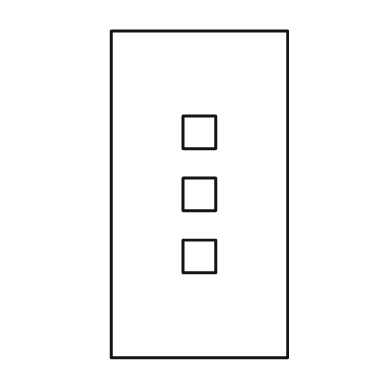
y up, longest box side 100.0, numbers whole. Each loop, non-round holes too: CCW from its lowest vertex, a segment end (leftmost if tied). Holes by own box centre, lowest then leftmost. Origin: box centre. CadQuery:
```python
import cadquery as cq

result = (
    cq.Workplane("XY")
    .moveTo(-27.0, -50.0)
    .lineTo(27.0, -50.0)
    .lineTo(27.0, 50.0)
    .lineTo(-27.0, 50.0)
    .close()
    .moveTo(-5.0, -24.0)
    .lineTo(5.0, -24.0)
    .lineTo(5.0, -14.0)
    .lineTo(-5.0, -14.0)
    .close()
    .moveTo(-5.0, -5.0)
    .lineTo(5.0, -5.0)
    .lineTo(5.0, 5.0)
    .lineTo(-5.0, 5.0)
    .close()
    .moveTo(-5.0, 14.0)
    .lineTo(5.0, 14.0)
    .lineTo(5.0, 24.0)
    .lineTo(-5.0, 24.0)
    .close()
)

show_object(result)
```